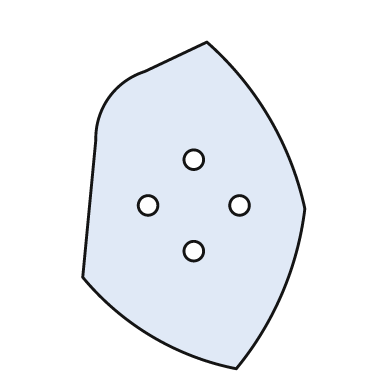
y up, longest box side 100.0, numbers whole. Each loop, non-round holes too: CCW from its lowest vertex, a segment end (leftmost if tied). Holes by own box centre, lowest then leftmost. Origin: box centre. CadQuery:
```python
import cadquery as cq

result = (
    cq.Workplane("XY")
    .moveTo(13.0, -50.0)
    .threePointArc((27.0, -27.0), (34.0, -1.0))
    .threePointArc((23.0, 27.0), (4.0, 50.0))
    .lineTo(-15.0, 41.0)
    .threePointArc((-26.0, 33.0), (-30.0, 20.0))
    .lineTo(-34.0, -22.0)
    .threePointArc((-13.0, -40.0), (13.0, -50.0))
    .close()
    .moveTo(0.0, -14.0)
    .circle(3.0)
    .moveTo(-14.0, 0.0)
    .circle(3.0)
    .moveTo(14.0, 0.0)
    .circle(3.0)
    .moveTo(0.0, 14.0)
    .circle(3.0)
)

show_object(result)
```